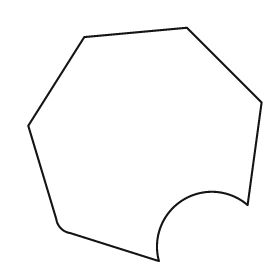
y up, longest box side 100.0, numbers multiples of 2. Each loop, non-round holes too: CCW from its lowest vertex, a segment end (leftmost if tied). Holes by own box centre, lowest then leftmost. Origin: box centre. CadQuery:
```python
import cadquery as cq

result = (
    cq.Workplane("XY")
    .moveTo(6.0, -50.0)
    .threePointArc((16.0, -24.0), (44.0, -26.0))
    .lineTo(50.0, 18.0)
    .lineTo(18.0, 50.0)
    .lineTo(-26.0, 46.0)
    .lineTo(-50.0, 8.0)
    .lineTo(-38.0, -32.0)
    .threePointArc((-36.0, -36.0), (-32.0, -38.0))
    .close()
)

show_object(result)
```